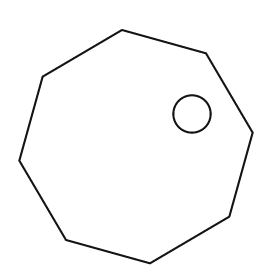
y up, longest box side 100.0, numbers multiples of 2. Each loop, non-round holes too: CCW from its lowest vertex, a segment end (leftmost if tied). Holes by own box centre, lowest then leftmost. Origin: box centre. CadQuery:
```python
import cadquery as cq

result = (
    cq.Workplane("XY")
    .moveTo(6.0, -50.0)
    .lineTo(40.0, -30.0)
    .lineTo(50.0, 6.0)
    .lineTo(30.0, 40.0)
    .lineTo(-6.0, 50.0)
    .lineTo(-40.0, 30.0)
    .lineTo(-50.0, -6.0)
    .lineTo(-30.0, -40.0)
    .close()
    .moveTo(24.0, 14.0)
    .circle(8.0)
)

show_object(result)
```